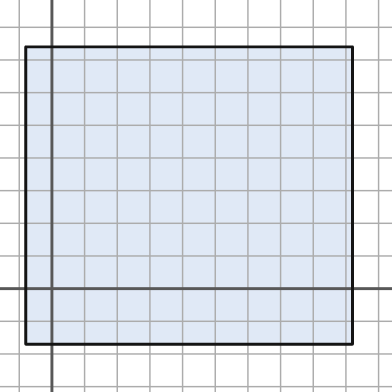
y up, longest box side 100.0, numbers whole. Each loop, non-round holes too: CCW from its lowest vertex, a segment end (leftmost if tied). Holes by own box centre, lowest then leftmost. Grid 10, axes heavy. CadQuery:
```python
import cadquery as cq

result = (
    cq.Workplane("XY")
    .moveTo(-8.0, -17.0)
    .lineTo(92.0, -17.0)
    .lineTo(92.0, 74.0)
    .lineTo(-8.0, 74.0)
    .close()
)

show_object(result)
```